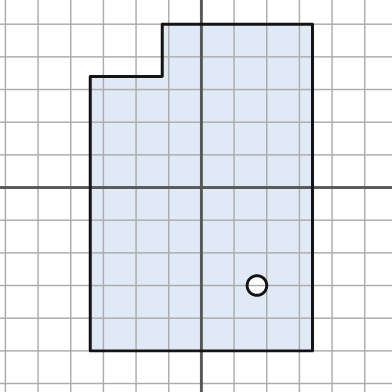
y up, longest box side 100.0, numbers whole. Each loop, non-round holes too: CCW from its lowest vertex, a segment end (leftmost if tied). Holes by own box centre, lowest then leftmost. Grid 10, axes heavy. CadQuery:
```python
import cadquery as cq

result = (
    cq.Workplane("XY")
    .moveTo(-34.0, -50.0)
    .lineTo(34.0, -50.0)
    .lineTo(34.0, 50.0)
    .lineTo(-12.0, 50.0)
    .lineTo(-12.0, 34.0)
    .lineTo(-34.0, 34.0)
    .close()
    .moveTo(17.0, -30.0)
    .circle(3.0)
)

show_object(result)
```